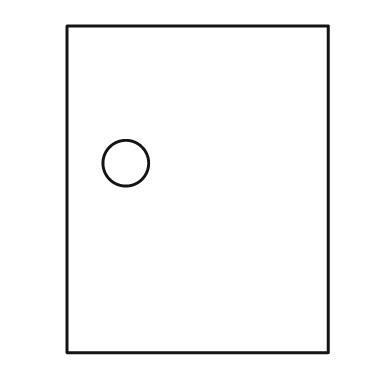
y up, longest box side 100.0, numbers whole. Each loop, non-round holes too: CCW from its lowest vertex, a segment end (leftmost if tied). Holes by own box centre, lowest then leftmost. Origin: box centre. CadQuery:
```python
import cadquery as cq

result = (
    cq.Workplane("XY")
    .moveTo(-40.0, -50.0)
    .lineTo(40.0, -50.0)
    .lineTo(40.0, 50.0)
    .lineTo(-40.0, 50.0)
    .close()
    .moveTo(-22.0, 8.0)
    .circle(7.0)
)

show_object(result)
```